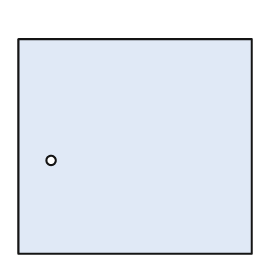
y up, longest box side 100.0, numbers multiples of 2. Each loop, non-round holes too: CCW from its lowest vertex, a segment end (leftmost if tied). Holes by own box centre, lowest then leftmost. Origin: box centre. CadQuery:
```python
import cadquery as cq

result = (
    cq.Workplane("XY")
    .moveTo(-50.0, -46.0)
    .lineTo(50.0, -46.0)
    .lineTo(50.0, 46.0)
    .lineTo(-50.0, 46.0)
    .close()
    .moveTo(-36.0, -6.0)
    .circle(2.0)
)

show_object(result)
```